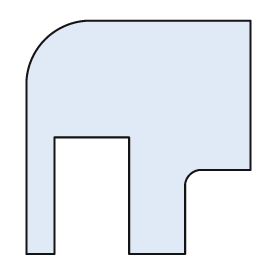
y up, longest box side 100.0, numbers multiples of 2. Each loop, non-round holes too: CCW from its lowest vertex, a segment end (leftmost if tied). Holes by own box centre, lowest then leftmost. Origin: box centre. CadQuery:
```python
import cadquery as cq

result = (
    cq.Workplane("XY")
    .moveTo(-48.0, -50.0)
    .lineTo(-36.0, -50.0)
    .lineTo(-36.0, 0.0)
    .lineTo(-4.0, 0.0)
    .lineTo(-4.0, -50.0)
    .lineTo(20.0, -50.0)
    .lineTo(20.0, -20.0)
    .threePointArc((22.0, -16.0), (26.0, -14.0))
    .lineTo(48.0, -14.0)
    .lineTo(48.0, 50.0)
    .lineTo(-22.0, 50.0)
    .threePointArc((-40.0, 42.0), (-48.0, 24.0))
    .close()
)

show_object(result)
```